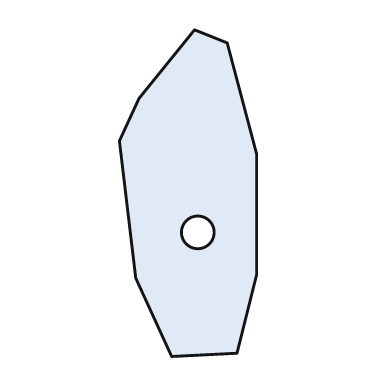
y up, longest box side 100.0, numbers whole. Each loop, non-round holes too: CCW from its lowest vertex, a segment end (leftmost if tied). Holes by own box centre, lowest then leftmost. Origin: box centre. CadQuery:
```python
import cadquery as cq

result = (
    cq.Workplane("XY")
    .moveTo(-5.0, -50.0)
    .lineTo(15.0, -49.0)
    .lineTo(21.0, -25.0)
    .lineTo(21.0, 12.0)
    .lineTo(12.0, 46.0)
    .lineTo(2.0, 50.0)
    .lineTo(-15.0, 29.0)
    .lineTo(-21.0, 16.0)
    .lineTo(-16.0, -26.0)
    .close()
    .moveTo(3.0, -12.0)
    .circle(5.0)
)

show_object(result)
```